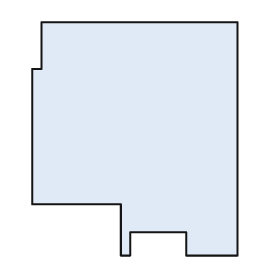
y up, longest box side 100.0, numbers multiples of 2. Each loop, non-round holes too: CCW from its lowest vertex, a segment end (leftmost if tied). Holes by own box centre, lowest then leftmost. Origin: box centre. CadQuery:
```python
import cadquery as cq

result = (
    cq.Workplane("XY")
    .moveTo(-6.0, -50.0)
    .lineTo(-2.0, -50.0)
    .lineTo(-2.0, -40.0)
    .lineTo(22.0, -40.0)
    .lineTo(22.0, -50.0)
    .lineTo(44.0, -50.0)
    .lineTo(44.0, 50.0)
    .lineTo(-40.0, 50.0)
    .lineTo(-40.0, 30.0)
    .lineTo(-44.0, 30.0)
    .lineTo(-44.0, -28.0)
    .lineTo(-6.0, -28.0)
    .close()
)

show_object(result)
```